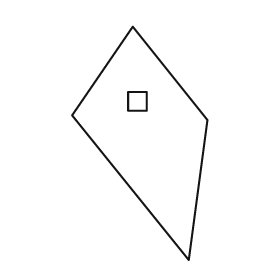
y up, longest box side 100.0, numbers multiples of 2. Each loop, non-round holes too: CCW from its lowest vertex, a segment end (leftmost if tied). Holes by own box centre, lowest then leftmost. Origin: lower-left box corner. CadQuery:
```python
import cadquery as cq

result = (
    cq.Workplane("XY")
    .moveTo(50.0, 0.0)
    .lineTo(58.0, 60.0)
    .lineTo(26.0, 100.0)
    .lineTo(0.0, 62.0)
    .close()
    .moveTo(24.0, 64.0)
    .lineTo(32.0, 64.0)
    .lineTo(32.0, 72.0)
    .lineTo(24.0, 72.0)
    .close()
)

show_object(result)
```